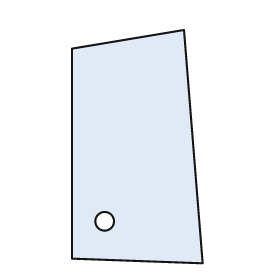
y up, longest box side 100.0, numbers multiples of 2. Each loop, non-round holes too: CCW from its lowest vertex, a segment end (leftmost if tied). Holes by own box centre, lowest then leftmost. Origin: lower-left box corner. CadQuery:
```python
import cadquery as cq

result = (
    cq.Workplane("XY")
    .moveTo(56.0, 0.0)
    .lineTo(48.0, 100.0)
    .lineTo(0.0, 92.0)
    .lineTo(0.0, 2.0)
    .close()
    .moveTo(14.0, 18.0)
    .circle(4.0)
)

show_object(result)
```